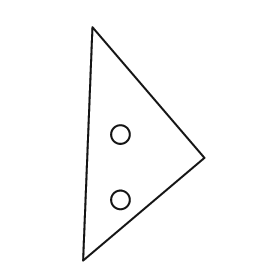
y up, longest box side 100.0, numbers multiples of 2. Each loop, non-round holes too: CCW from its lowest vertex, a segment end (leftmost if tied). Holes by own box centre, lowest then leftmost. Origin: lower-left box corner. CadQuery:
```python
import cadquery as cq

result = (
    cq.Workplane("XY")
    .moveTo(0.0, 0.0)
    .lineTo(52.0, 44.0)
    .lineTo(4.0, 100.0)
    .close()
    .moveTo(16.0, 26.0)
    .circle(4.0)
    .moveTo(16.0, 54.0)
    .circle(4.0)
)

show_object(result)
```